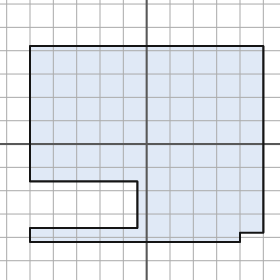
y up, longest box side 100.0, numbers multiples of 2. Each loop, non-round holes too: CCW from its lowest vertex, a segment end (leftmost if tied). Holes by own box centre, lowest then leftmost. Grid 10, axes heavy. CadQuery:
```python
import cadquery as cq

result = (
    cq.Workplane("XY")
    .moveTo(-50.0, -42.0)
    .lineTo(40.0, -42.0)
    .lineTo(40.0, -38.0)
    .lineTo(50.0, -38.0)
    .lineTo(50.0, 42.0)
    .lineTo(-50.0, 42.0)
    .lineTo(-50.0, -16.0)
    .lineTo(-4.0, -16.0)
    .lineTo(-4.0, -36.0)
    .lineTo(-50.0, -36.0)
    .close()
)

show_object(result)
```